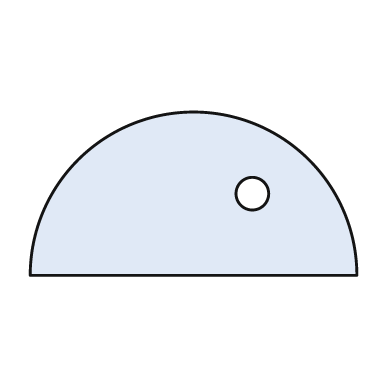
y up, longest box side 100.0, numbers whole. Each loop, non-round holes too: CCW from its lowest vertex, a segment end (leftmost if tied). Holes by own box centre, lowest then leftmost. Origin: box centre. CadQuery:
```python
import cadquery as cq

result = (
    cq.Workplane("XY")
    .moveTo(-50.0, -25.0)
    .lineTo(50.0, -25.0)
    .threePointArc((0.0, 25.0), (-50.0, -25.0))
    .close()
    .moveTo(18.0, 0.0)
    .circle(5.0)
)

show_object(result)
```